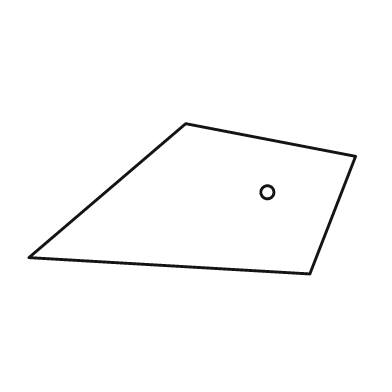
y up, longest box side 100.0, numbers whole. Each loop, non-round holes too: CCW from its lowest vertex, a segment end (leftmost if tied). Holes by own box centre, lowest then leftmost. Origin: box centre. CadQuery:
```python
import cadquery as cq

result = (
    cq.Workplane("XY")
    .moveTo(36.0, -23.0)
    .lineTo(50.0, 13.0)
    .lineTo(-2.0, 23.0)
    .lineTo(-50.0, -18.0)
    .close()
    .moveTo(23.0, 2.0)
    .circle(2.0)
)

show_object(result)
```